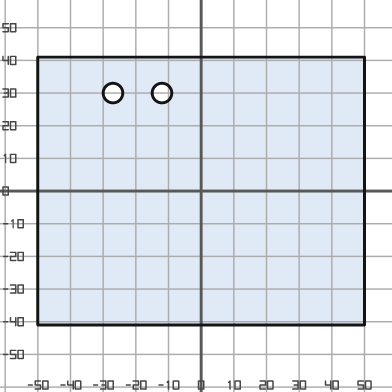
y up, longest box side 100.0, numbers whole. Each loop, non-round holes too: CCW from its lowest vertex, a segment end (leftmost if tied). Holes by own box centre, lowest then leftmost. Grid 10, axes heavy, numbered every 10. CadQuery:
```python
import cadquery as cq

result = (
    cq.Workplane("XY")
    .moveTo(-50.0, -41.0)
    .lineTo(50.0, -41.0)
    .lineTo(50.0, 41.0)
    .lineTo(-50.0, 41.0)
    .close()
    .moveTo(-27.0, 30.0)
    .circle(3.0)
    .moveTo(-12.0, 30.0)
    .circle(3.0)
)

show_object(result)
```